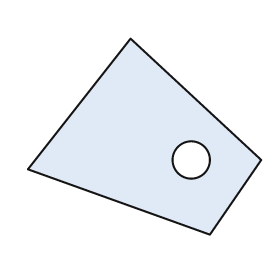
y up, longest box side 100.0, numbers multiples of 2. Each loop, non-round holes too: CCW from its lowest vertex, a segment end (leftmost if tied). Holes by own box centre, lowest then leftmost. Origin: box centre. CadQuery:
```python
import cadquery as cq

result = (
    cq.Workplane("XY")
    .moveTo(28.0, -42.0)
    .lineTo(50.0, -10.0)
    .lineTo(-6.0, 42.0)
    .lineTo(-50.0, -14.0)
    .close()
    .moveTo(20.0, -10.0)
    .circle(8.0)
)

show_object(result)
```